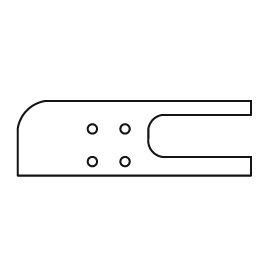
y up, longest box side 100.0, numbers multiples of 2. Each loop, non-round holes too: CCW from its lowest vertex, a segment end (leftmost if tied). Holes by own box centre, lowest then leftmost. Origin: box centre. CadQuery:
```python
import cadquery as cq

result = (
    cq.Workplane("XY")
    .moveTo(-50.0, -16.0)
    .lineTo(50.0, -16.0)
    .lineTo(50.0, -8.0)
    .lineTo(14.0, -8.0)
    .threePointArc((8.0, -6.0), (6.0, 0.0))
    .lineTo(6.0, 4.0)
    .threePointArc((8.0, 8.0), (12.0, 10.0))
    .lineTo(50.0, 10.0)
    .lineTo(50.0, 16.0)
    .lineTo(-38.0, 16.0)
    .threePointArc((-46.0, 12.0), (-50.0, 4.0))
    .close()
    .moveTo(-18.0, -10.0)
    .circle(2.0)
    .moveTo(-4.0, -10.0)
    .circle(2.0)
    .moveTo(-18.0, 4.0)
    .circle(2.0)
    .moveTo(-4.0, 4.0)
    .circle(2.0)
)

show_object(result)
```